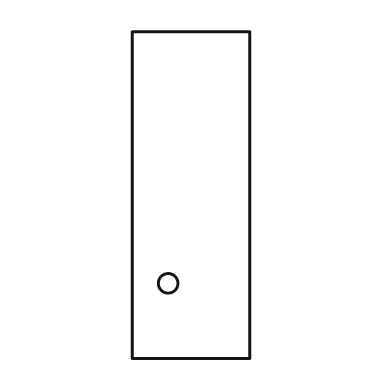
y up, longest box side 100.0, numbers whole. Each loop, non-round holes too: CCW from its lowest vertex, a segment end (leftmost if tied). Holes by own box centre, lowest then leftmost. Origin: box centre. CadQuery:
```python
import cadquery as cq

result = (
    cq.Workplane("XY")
    .moveTo(-18.0, -50.0)
    .lineTo(18.0, -50.0)
    .lineTo(18.0, 50.0)
    .lineTo(-18.0, 50.0)
    .close()
    .moveTo(-7.0, -27.0)
    .circle(3.0)
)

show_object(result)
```